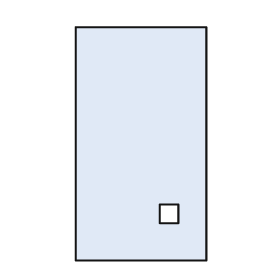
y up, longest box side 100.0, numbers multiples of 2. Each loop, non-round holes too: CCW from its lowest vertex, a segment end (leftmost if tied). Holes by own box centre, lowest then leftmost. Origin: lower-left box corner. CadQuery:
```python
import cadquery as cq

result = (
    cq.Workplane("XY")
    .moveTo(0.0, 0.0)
    .lineTo(56.0, 0.0)
    .lineTo(56.0, 100.0)
    .lineTo(0.0, 100.0)
    .close()
    .moveTo(36.0, 16.0)
    .lineTo(44.0, 16.0)
    .lineTo(44.0, 24.0)
    .lineTo(36.0, 24.0)
    .close()
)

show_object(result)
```